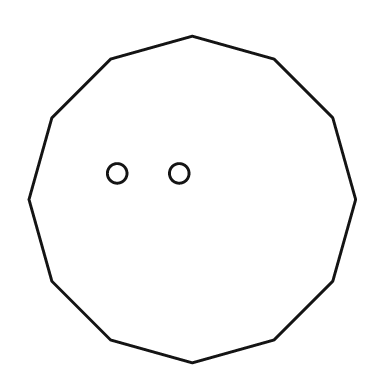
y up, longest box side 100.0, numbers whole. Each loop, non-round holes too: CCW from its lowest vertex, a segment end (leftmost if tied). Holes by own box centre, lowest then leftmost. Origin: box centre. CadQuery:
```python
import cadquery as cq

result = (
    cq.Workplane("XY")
    .moveTo(0.0, -50.0)
    .lineTo(25.0, -43.0)
    .lineTo(43.0, -25.0)
    .lineTo(50.0, 0.0)
    .lineTo(43.0, 25.0)
    .lineTo(25.0, 43.0)
    .lineTo(0.0, 50.0)
    .lineTo(-25.0, 43.0)
    .lineTo(-43.0, 25.0)
    .lineTo(-50.0, 0.0)
    .lineTo(-43.0, -25.0)
    .lineTo(-25.0, -43.0)
    .close()
    .moveTo(-23.0, 8.0)
    .circle(3.0)
    .moveTo(-4.0, 8.0)
    .circle(3.0)
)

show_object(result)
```